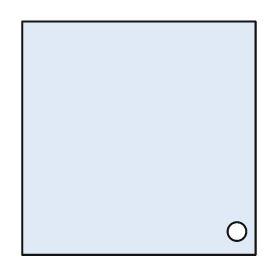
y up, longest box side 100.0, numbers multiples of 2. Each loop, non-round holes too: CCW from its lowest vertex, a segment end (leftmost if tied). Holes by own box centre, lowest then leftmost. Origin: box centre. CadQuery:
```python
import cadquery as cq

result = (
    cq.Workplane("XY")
    .moveTo(-50.0, -50.0)
    .lineTo(50.0, -50.0)
    .lineTo(50.0, 50.0)
    .lineTo(-50.0, 50.0)
    .close()
    .moveTo(42.0, -40.0)
    .circle(4.0)
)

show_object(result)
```